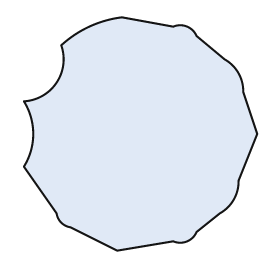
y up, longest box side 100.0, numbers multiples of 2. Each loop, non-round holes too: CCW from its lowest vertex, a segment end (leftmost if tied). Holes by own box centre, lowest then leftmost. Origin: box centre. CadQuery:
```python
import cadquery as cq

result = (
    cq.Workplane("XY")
    .moveTo(-10.0, -50.0)
    .lineTo(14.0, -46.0)
    .threePointArc((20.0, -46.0), (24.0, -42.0))
    .lineTo(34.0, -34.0)
    .threePointArc((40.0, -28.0), (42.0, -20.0))
    .lineTo(50.0, 0.0)
    .lineTo(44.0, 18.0)
    .threePointArc((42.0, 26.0), (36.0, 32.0))
    .lineTo(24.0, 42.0)
    .threePointArc((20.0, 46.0), (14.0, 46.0))
    .lineTo(-8.0, 50.0)
    .threePointArc((-22.0, 46.0), (-34.0, 38.0))
    .threePointArc((-36.0, 22.0), (-50.0, 14.0))
    .threePointArc((-46.0, 0.0), (-50.0, -14.0))
    .lineTo(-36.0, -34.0)
    .threePointArc((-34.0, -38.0), (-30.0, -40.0))
    .close()
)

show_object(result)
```